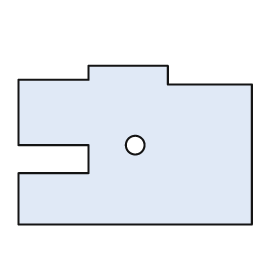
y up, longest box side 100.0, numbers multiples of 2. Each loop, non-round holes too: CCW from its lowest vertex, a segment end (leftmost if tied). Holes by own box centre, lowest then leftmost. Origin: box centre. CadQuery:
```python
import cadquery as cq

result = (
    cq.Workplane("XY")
    .moveTo(-50.0, -34.0)
    .lineTo(50.0, -34.0)
    .lineTo(50.0, 26.0)
    .lineTo(14.0, 26.0)
    .lineTo(14.0, 34.0)
    .lineTo(-20.0, 34.0)
    .lineTo(-20.0, 28.0)
    .lineTo(-50.0, 28.0)
    .lineTo(-50.0, 0.0)
    .lineTo(-20.0, 0.0)
    .lineTo(-20.0, -12.0)
    .lineTo(-50.0, -12.0)
    .close()
    .moveTo(0.0, 0.0)
    .circle(4.0)
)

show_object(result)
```